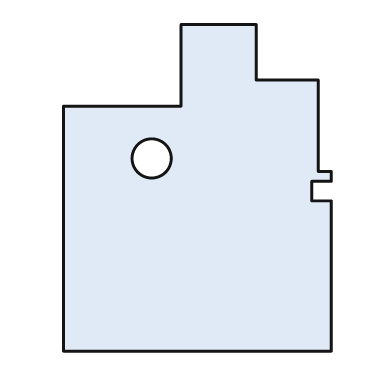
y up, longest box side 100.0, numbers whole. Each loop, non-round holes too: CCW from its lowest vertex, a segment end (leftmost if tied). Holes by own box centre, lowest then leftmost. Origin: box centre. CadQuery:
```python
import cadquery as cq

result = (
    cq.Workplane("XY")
    .moveTo(-41.0, -50.0)
    .lineTo(41.0, -50.0)
    .lineTo(41.0, -4.0)
    .lineTo(35.0, -4.0)
    .lineTo(35.0, 2.0)
    .lineTo(41.0, 2.0)
    .lineTo(41.0, 5.0)
    .lineTo(37.0, 5.0)
    .lineTo(37.0, 33.0)
    .lineTo(18.0, 33.0)
    .lineTo(18.0, 50.0)
    .lineTo(-5.0, 50.0)
    .lineTo(-5.0, 25.0)
    .lineTo(-41.0, 25.0)
    .close()
    .moveTo(-14.0, 9.0)
    .circle(6.0)
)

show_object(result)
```